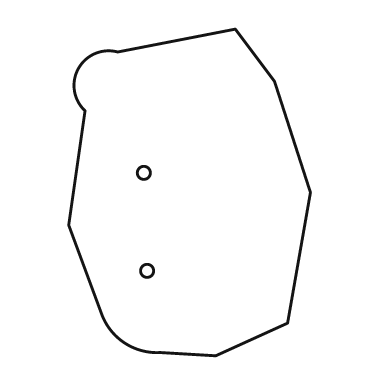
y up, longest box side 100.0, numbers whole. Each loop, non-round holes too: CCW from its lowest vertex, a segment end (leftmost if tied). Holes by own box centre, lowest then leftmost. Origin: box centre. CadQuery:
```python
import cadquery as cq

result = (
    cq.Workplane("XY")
    .moveTo(8.0, -50.0)
    .lineTo(30.0, -40.0)
    .lineTo(37.0, 0.0)
    .lineTo(26.0, 34.0)
    .lineTo(14.0, 50.0)
    .lineTo(-22.0, 43.0)
    .threePointArc((-34.0, 38.0), (-32.0, 25.0))
    .lineTo(-37.0, -10.0)
    .lineTo(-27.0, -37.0)
    .threePointArc((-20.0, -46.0), (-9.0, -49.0))
    .close()
    .moveTo(-13.0, -24.0)
    .circle(2.0)
    .moveTo(-14.0, 6.0)
    .circle(2.0)
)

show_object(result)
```